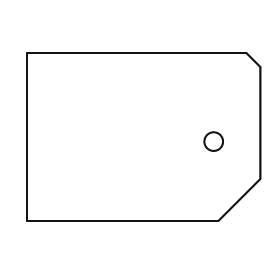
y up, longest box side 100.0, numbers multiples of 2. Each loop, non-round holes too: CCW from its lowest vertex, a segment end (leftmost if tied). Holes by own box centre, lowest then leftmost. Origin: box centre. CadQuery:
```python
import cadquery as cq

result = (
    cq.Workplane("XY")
    .moveTo(-50.0, -36.0)
    .lineTo(32.0, -36.0)
    .lineTo(50.0, -18.0)
    .lineTo(50.0, 30.0)
    .lineTo(44.0, 36.0)
    .lineTo(-50.0, 36.0)
    .close()
    .moveTo(30.0, -2.0)
    .circle(4.0)
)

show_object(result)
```